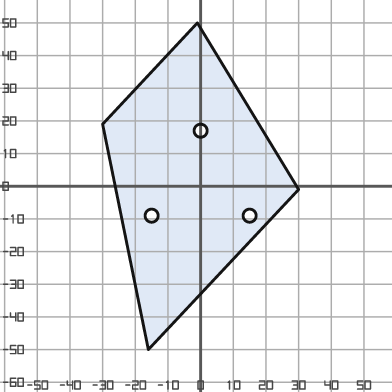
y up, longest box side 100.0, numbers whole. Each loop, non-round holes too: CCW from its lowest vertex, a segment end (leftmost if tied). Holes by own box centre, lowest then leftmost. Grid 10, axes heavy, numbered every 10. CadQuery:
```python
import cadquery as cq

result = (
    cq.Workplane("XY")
    .moveTo(-16.0, -50.0)
    .lineTo(30.0, -1.0)
    .lineTo(-1.0, 50.0)
    .lineTo(-30.0, 19.0)
    .close()
    .moveTo(-15.0, -9.0)
    .circle(2.0)
    .moveTo(15.0, -9.0)
    .circle(2.0)
    .moveTo(0.0, 17.0)
    .circle(2.0)
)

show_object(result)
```